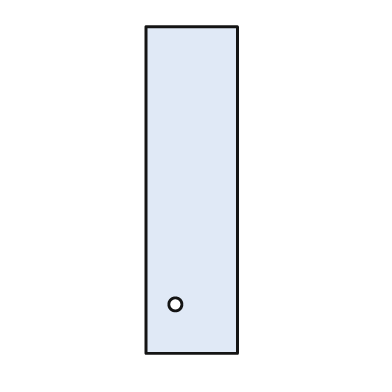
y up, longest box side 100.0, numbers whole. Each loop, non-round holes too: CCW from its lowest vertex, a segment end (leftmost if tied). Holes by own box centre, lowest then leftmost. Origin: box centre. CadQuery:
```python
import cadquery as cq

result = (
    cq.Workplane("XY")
    .moveTo(-14.0, -50.0)
    .lineTo(14.0, -50.0)
    .lineTo(14.0, 50.0)
    .lineTo(-14.0, 50.0)
    .close()
    .moveTo(-5.0, -35.0)
    .circle(2.0)
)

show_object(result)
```